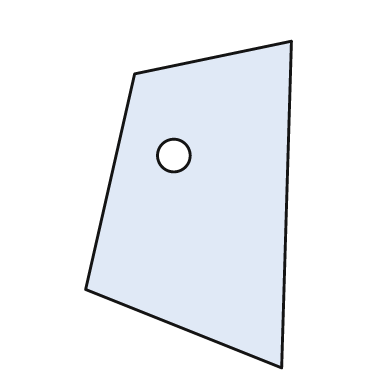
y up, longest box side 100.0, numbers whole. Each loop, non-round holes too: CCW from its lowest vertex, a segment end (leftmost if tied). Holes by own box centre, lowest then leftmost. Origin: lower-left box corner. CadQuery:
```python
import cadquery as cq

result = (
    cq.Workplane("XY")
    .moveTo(60.0, 0.0)
    .lineTo(63.0, 100.0)
    .lineTo(15.0, 90.0)
    .lineTo(0.0, 24.0)
    .close()
    .moveTo(27.0, 65.0)
    .circle(5.0)
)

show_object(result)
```